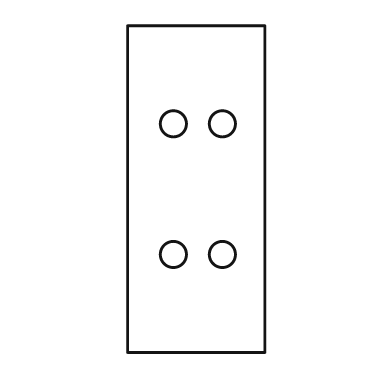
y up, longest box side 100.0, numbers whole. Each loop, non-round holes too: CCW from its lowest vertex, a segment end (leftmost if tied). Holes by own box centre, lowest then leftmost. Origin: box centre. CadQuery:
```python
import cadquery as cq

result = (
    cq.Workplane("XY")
    .moveTo(-21.0, -50.0)
    .lineTo(21.0, -50.0)
    .lineTo(21.0, 50.0)
    .lineTo(-21.0, 50.0)
    .close()
    .moveTo(-7.0, -20.0)
    .circle(4.0)
    .moveTo(8.0, -20.0)
    .circle(4.0)
    .moveTo(-7.0, 20.0)
    .circle(4.0)
    .moveTo(8.0, 20.0)
    .circle(4.0)
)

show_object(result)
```